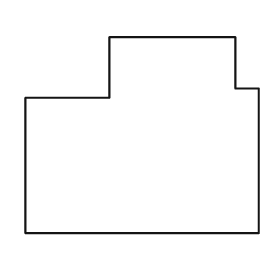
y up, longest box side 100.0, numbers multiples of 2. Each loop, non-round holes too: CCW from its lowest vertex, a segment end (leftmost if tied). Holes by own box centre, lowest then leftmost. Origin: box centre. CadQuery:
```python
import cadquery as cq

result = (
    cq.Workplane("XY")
    .moveTo(-50.0, -42.0)
    .lineTo(50.0, -42.0)
    .lineTo(50.0, 20.0)
    .lineTo(40.0, 20.0)
    .lineTo(40.0, 42.0)
    .lineTo(-14.0, 42.0)
    .lineTo(-14.0, 16.0)
    .lineTo(-50.0, 16.0)
    .close()
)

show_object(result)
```